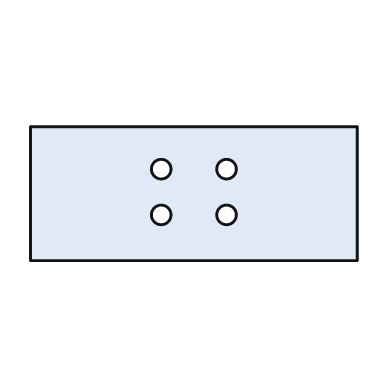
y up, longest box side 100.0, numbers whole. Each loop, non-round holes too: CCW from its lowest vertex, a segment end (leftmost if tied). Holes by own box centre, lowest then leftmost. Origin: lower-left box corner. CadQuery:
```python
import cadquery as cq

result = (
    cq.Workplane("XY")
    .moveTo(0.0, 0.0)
    .lineTo(100.0, 0.0)
    .lineTo(100.0, 41.0)
    .lineTo(0.0, 41.0)
    .close()
    .moveTo(40.0, 14.0)
    .circle(3.0)
    .moveTo(60.0, 14.0)
    .circle(3.0)
    .moveTo(40.0, 28.0)
    .circle(3.0)
    .moveTo(60.0, 28.0)
    .circle(3.0)
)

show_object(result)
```